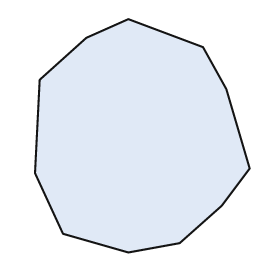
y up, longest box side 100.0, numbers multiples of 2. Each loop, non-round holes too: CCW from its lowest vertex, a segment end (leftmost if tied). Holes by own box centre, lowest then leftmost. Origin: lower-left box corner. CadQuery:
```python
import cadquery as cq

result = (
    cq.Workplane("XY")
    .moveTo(40.0, 0.0)
    .lineTo(62.0, 4.0)
    .lineTo(80.0, 20.0)
    .lineTo(92.0, 36.0)
    .lineTo(82.0, 70.0)
    .lineTo(72.0, 88.0)
    .lineTo(40.0, 100.0)
    .lineTo(22.0, 92.0)
    .lineTo(2.0, 74.0)
    .lineTo(0.0, 34.0)
    .lineTo(12.0, 8.0)
    .close()
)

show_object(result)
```